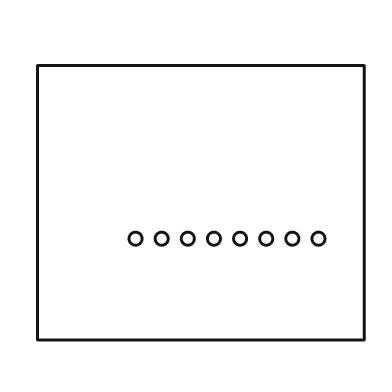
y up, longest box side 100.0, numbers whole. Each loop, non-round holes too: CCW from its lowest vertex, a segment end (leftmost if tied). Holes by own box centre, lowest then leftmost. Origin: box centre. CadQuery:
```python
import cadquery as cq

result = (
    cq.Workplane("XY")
    .moveTo(-50.0, -42.0)
    .lineTo(50.0, -42.0)
    .lineTo(50.0, 42.0)
    .lineTo(-50.0, 42.0)
    .close()
    .moveTo(-20.0, -11.0)
    .circle(2.0)
    .moveTo(-12.0, -11.0)
    .circle(2.0)
    .moveTo(-4.0, -11.0)
    .circle(2.0)
    .moveTo(4.0, -11.0)
    .circle(2.0)
    .moveTo(12.0, -11.0)
    .circle(2.0)
    .moveTo(20.0, -11.0)
    .circle(2.0)
    .moveTo(28.0, -11.0)
    .circle(2.0)
    .moveTo(36.0, -11.0)
    .circle(2.0)
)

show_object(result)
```